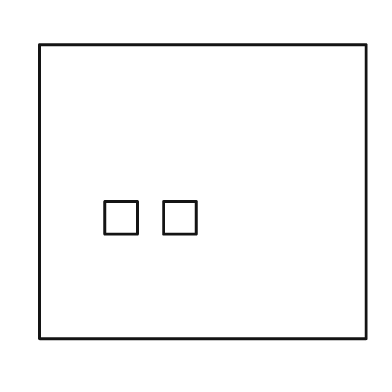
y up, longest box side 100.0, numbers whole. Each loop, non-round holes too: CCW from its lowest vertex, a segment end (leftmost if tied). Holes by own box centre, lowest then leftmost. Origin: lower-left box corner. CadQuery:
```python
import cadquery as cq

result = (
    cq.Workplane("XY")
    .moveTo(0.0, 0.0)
    .lineTo(100.0, 0.0)
    .lineTo(100.0, 90.0)
    .lineTo(0.0, 90.0)
    .close()
    .moveTo(20.0, 32.0)
    .lineTo(30.0, 32.0)
    .lineTo(30.0, 42.0)
    .lineTo(20.0, 42.0)
    .close()
    .moveTo(38.0, 32.0)
    .lineTo(48.0, 32.0)
    .lineTo(48.0, 42.0)
    .lineTo(38.0, 42.0)
    .close()
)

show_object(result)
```